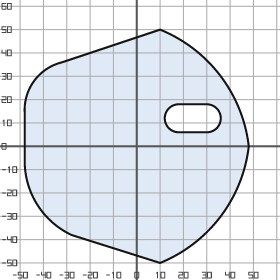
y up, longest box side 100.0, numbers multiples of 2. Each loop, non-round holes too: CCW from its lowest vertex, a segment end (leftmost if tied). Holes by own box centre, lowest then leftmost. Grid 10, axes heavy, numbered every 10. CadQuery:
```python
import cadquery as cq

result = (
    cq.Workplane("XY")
    .moveTo(10.0, -50.0)
    .threePointArc((36.0, -30.0), (48.0, 0.0))
    .threePointArc((36.0, 30.0), (10.0, 50.0))
    .lineTo(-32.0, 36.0)
    .threePointArc((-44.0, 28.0), (-48.0, 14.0))
    .lineTo(-48.0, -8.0)
    .threePointArc((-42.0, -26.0), (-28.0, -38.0))
    .close()
    .moveTo(18.0, 6.0)
    .lineTo(30.0, 6.0)
    .threePointArc((36.0, 12.0), (30.0, 18.0))
    .lineTo(18.0, 18.0)
    .threePointArc((12.0, 12.0), (18.0, 6.0))
    .close()
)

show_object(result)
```